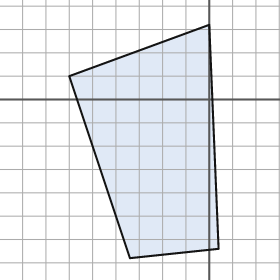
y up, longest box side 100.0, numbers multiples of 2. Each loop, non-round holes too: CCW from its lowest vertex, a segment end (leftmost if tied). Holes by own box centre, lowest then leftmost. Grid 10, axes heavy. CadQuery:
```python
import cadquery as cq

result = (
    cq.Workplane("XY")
    .moveTo(-34.0, -68.0)
    .lineTo(4.0, -64.0)
    .lineTo(0.0, 32.0)
    .lineTo(-60.0, 10.0)
    .close()
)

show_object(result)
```